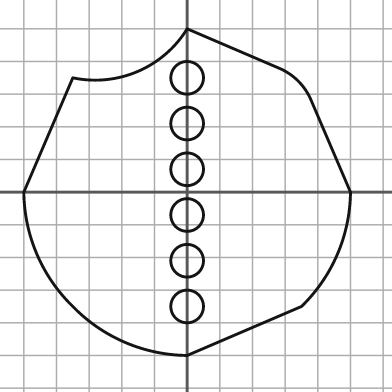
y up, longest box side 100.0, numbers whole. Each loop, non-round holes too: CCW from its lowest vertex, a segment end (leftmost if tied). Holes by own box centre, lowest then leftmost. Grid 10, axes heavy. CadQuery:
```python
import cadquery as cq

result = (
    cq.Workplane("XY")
    .moveTo(0.0, -50.0)
    .lineTo(35.0, -35.0)
    .threePointArc((46.0, -19.0), (50.0, 0.0))
    .lineTo(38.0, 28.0)
    .threePointArc((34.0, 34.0), (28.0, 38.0))
    .lineTo(0.0, 50.0)
    .threePointArc((-15.0, 37.0), (-35.0, 35.0))
    .lineTo(-50.0, 0.0)
    .threePointArc((-46.0, -19.0), (-35.0, -35.0))
    .threePointArc((-19.0, -46.0), (0.0, -50.0))
    .close()
    .moveTo(0.0, -35.0)
    .circle(5.0)
    .moveTo(0.0, -21.0)
    .circle(5.0)
    .moveTo(0.0, -7.0)
    .circle(5.0)
    .moveTo(0.0, 7.0)
    .circle(5.0)
    .moveTo(0.0, 21.0)
    .circle(5.0)
    .moveTo(0.0, 35.0)
    .circle(5.0)
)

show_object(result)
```